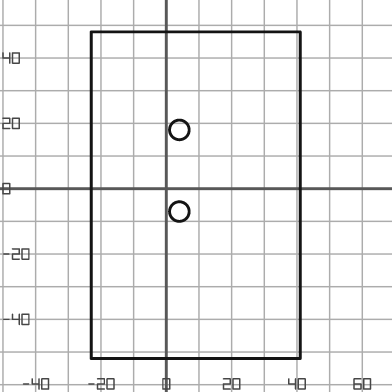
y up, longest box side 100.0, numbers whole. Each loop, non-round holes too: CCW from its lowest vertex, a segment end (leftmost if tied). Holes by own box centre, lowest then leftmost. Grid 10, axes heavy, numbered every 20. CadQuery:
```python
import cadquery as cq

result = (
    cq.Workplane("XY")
    .moveTo(-23.0, -52.0)
    .lineTo(41.0, -52.0)
    .lineTo(41.0, 48.0)
    .lineTo(-23.0, 48.0)
    .close()
    .moveTo(4.0, -7.0)
    .circle(3.0)
    .moveTo(4.0, 18.0)
    .circle(3.0)
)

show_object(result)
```